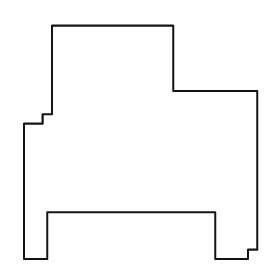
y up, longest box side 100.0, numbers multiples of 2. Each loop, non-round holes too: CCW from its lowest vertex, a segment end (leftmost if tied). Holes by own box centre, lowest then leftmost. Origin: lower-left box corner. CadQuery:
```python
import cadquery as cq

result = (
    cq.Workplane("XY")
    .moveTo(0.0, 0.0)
    .lineTo(10.0, 0.0)
    .lineTo(10.0, 20.0)
    .lineTo(82.0, 20.0)
    .lineTo(82.0, 0.0)
    .lineTo(96.0, 0.0)
    .lineTo(96.0, 4.0)
    .lineTo(100.0, 4.0)
    .lineTo(100.0, 72.0)
    .lineTo(64.0, 72.0)
    .lineTo(64.0, 100.0)
    .lineTo(12.0, 100.0)
    .lineTo(12.0, 62.0)
    .lineTo(8.0, 62.0)
    .lineTo(8.0, 58.0)
    .lineTo(0.0, 58.0)
    .close()
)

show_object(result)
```